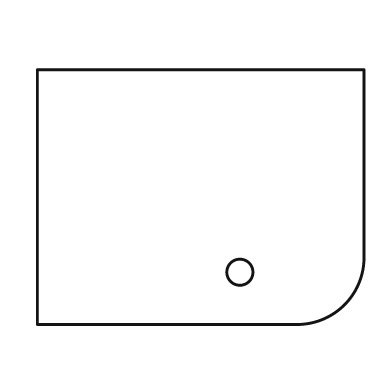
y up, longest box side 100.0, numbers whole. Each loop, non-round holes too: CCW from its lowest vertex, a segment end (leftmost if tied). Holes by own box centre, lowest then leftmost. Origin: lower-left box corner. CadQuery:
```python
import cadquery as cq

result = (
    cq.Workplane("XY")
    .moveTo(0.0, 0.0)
    .lineTo(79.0, 0.0)
    .threePointArc((94.0, 6.0), (100.0, 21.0))
    .lineTo(100.0, 78.0)
    .lineTo(0.0, 78.0)
    .close()
    .moveTo(62.0, 16.0)
    .circle(4.0)
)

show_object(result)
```